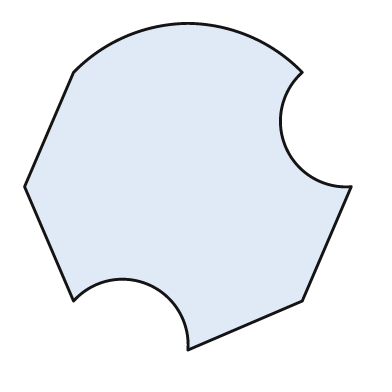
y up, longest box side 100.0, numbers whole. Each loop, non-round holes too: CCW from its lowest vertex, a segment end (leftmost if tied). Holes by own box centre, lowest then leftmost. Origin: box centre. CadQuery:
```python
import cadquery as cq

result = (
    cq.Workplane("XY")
    .moveTo(0.0, -50.0)
    .lineTo(35.0, -35.0)
    .lineTo(50.0, 0.0)
    .threePointArc((30.0, 12.0), (35.0, 35.0))
    .threePointArc((19.0, 46.0), (0.0, 50.0))
    .threePointArc((-19.0, 46.0), (-35.0, 35.0))
    .lineTo(-50.0, 0.0)
    .lineTo(-35.0, -35.0)
    .threePointArc((-12.0, -30.0), (0.0, -50.0))
    .close()
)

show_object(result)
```